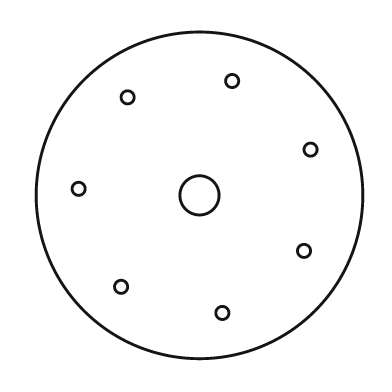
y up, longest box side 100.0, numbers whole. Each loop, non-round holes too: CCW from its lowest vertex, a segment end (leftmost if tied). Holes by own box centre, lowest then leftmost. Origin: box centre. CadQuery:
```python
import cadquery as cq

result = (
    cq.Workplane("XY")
    .moveTo(0.0, 0.0)
    .circle(50.0)
    .moveTo(7.0, -36.0)
    .circle(2.0)
    .moveTo(-24.0, -28.0)
    .circle(2.0)
    .moveTo(32.0, -17.0)
    .circle(2.0)
    .moveTo(0.0, 0.0)
    .circle(6.0)
    .moveTo(-37.0, 2.0)
    .circle(2.0)
    .moveTo(34.0, 14.0)
    .circle(2.0)
    .moveTo(-22.0, 30.0)
    .circle(2.0)
    .moveTo(10.0, 35.0)
    .circle(2.0)
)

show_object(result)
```